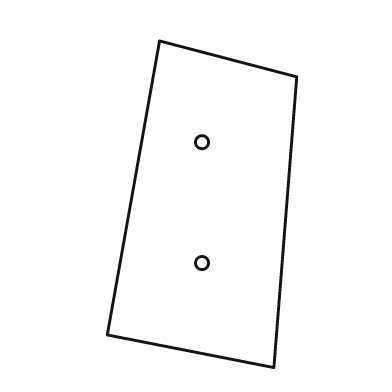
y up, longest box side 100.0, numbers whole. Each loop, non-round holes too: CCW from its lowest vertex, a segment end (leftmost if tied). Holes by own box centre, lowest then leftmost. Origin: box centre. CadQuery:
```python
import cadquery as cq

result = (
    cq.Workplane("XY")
    .moveTo(22.0, -50.0)
    .lineTo(29.0, 39.0)
    .lineTo(-13.0, 50.0)
    .lineTo(-29.0, -40.0)
    .close()
    .moveTo(0.0, -18.0)
    .circle(2.0)
    .moveTo(0.0, 19.0)
    .circle(2.0)
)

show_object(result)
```